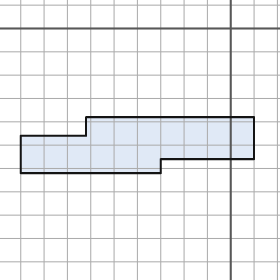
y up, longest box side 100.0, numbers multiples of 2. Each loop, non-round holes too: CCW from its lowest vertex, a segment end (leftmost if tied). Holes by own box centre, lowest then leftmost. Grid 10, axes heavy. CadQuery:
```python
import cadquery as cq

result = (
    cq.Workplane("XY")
    .moveTo(-90.0, -62.0)
    .lineTo(-30.0, -62.0)
    .lineTo(-30.0, -56.0)
    .lineTo(10.0, -56.0)
    .lineTo(10.0, -38.0)
    .lineTo(-62.0, -38.0)
    .lineTo(-62.0, -46.0)
    .lineTo(-90.0, -46.0)
    .close()
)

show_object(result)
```